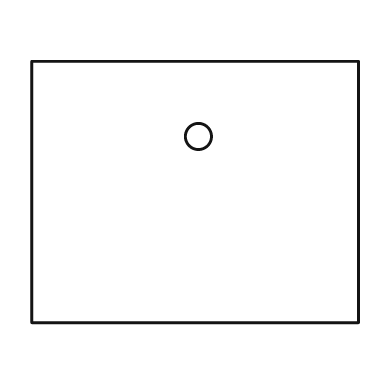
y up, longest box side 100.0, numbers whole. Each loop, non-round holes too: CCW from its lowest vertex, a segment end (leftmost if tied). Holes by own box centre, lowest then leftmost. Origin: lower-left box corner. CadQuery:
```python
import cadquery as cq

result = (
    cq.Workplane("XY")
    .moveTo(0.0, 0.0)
    .lineTo(100.0, 0.0)
    .lineTo(100.0, 80.0)
    .lineTo(0.0, 80.0)
    .close()
    .moveTo(51.0, 57.0)
    .circle(4.0)
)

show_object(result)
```